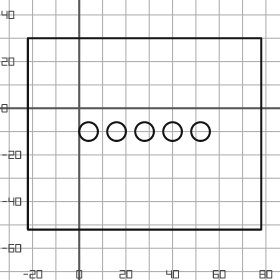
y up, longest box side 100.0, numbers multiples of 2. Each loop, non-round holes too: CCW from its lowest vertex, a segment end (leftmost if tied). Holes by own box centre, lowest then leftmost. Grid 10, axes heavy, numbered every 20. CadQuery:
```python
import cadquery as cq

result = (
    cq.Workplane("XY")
    .moveTo(-22.0, -52.0)
    .lineTo(78.0, -52.0)
    .lineTo(78.0, 30.0)
    .lineTo(-22.0, 30.0)
    .close()
    .moveTo(4.0, -10.0)
    .circle(4.0)
    .moveTo(16.0, -10.0)
    .circle(4.0)
    .moveTo(28.0, -10.0)
    .circle(4.0)
    .moveTo(40.0, -10.0)
    .circle(4.0)
    .moveTo(52.0, -10.0)
    .circle(4.0)
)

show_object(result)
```